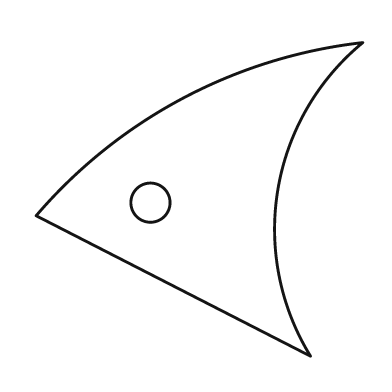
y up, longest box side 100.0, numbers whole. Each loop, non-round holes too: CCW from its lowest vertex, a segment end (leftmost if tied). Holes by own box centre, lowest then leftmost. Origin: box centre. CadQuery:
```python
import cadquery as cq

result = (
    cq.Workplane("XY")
    .moveTo(34.0, -48.0)
    .threePointArc((24.0, 3.0), (50.0, 48.0))
    .threePointArc((-5.0, 31.0), (-50.0, -5.0))
    .close()
    .moveTo(-15.0, -1.0)
    .circle(6.0)
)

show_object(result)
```